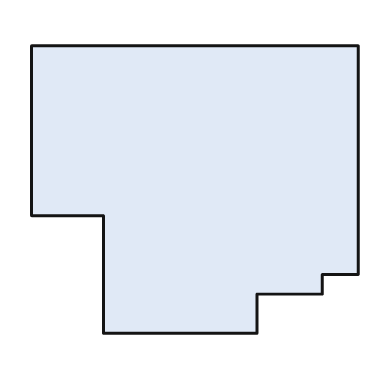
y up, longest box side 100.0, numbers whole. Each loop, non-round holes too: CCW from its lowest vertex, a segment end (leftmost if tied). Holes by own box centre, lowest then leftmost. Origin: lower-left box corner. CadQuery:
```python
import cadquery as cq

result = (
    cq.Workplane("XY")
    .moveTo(22.0, 0.0)
    .lineTo(69.0, 0.0)
    .lineTo(69.0, 12.0)
    .lineTo(89.0, 12.0)
    .lineTo(89.0, 18.0)
    .lineTo(100.0, 18.0)
    .lineTo(100.0, 88.0)
    .lineTo(0.0, 88.0)
    .lineTo(0.0, 36.0)
    .lineTo(22.0, 36.0)
    .close()
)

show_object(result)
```